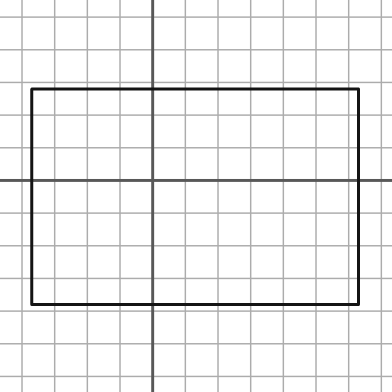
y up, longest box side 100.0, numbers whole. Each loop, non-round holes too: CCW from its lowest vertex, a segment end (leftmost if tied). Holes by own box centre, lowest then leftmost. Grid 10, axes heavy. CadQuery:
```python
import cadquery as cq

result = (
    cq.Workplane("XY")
    .moveTo(-37.0, -38.0)
    .lineTo(63.0, -38.0)
    .lineTo(63.0, 28.0)
    .lineTo(-37.0, 28.0)
    .close()
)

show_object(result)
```